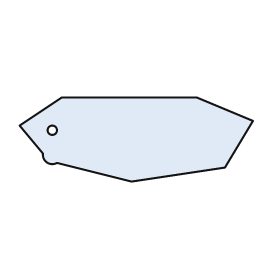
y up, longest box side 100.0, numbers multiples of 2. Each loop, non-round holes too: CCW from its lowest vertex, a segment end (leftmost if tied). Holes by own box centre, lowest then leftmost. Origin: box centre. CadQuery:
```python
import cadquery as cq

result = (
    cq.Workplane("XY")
    .moveTo(-2.0, -18.0)
    .lineTo(38.0, -12.0)
    .lineTo(50.0, 8.0)
    .lineTo(26.0, 18.0)
    .lineTo(-32.0, 18.0)
    .lineTo(-50.0, 6.0)
    .lineTo(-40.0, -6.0)
    .threePointArc((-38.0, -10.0), (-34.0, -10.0))
    .close()
    .moveTo(-36.0, 4.0)
    .circle(2.0)
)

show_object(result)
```